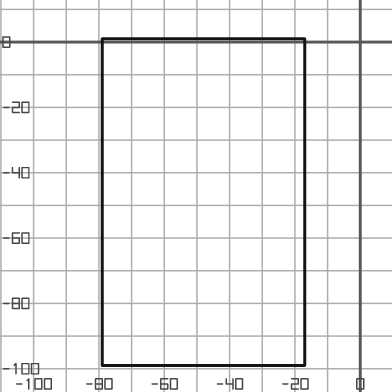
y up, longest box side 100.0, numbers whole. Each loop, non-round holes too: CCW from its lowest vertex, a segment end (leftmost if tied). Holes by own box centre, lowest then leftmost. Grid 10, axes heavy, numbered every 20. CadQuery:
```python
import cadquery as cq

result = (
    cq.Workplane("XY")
    .moveTo(-79.0, -99.0)
    .lineTo(-17.0, -99.0)
    .lineTo(-17.0, 1.0)
    .lineTo(-79.0, 1.0)
    .close()
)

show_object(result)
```